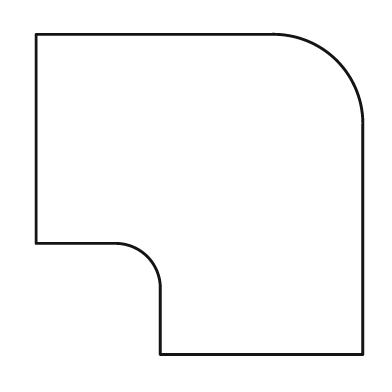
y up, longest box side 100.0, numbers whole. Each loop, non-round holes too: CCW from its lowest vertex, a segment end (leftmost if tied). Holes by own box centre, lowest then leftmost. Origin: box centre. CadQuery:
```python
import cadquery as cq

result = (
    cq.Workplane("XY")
    .moveTo(-12.0, -49.0)
    .lineTo(50.0, -49.0)
    .lineTo(50.0, 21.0)
    .threePointArc((42.0, 41.0), (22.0, 49.0))
    .lineTo(-50.0, 49.0)
    .lineTo(-50.0, -15.0)
    .lineTo(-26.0, -15.0)
    .threePointArc((-16.0, -19.0), (-12.0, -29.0))
    .close()
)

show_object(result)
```